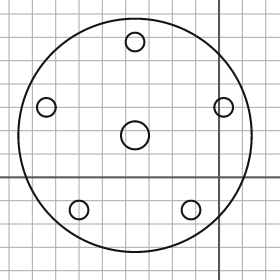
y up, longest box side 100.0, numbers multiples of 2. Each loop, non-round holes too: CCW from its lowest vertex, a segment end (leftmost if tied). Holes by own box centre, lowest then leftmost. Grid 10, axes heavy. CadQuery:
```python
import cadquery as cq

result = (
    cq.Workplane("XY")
    .moveTo(-36.0, 18.0)
    .circle(50.0)
    .moveTo(-60.0, -14.0)
    .circle(4.0)
    .moveTo(-12.0, -14.0)
    .circle(4.0)
    .moveTo(-36.0, 18.0)
    .circle(6.0)
    .moveTo(-74.0, 30.0)
    .circle(4.0)
    .moveTo(2.0, 30.0)
    .circle(4.0)
    .moveTo(-36.0, 58.0)
    .circle(4.0)
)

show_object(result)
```